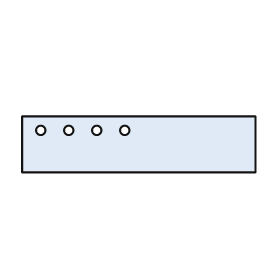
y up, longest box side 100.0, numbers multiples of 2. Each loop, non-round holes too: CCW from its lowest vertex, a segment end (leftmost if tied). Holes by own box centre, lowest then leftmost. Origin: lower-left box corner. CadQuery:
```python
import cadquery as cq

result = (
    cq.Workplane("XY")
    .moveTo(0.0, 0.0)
    .lineTo(100.0, 0.0)
    .lineTo(100.0, 24.0)
    .lineTo(0.0, 24.0)
    .close()
    .moveTo(8.0, 18.0)
    .circle(2.0)
    .moveTo(20.0, 18.0)
    .circle(2.0)
    .moveTo(32.0, 18.0)
    .circle(2.0)
    .moveTo(44.0, 18.0)
    .circle(2.0)
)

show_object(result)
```